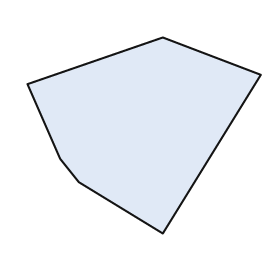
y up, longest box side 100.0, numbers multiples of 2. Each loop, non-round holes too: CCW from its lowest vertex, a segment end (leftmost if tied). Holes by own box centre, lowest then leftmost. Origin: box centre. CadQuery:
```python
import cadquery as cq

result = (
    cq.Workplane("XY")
    .moveTo(8.0, -42.0)
    .lineTo(50.0, 26.0)
    .lineTo(8.0, 42.0)
    .lineTo(-50.0, 22.0)
    .lineTo(-36.0, -10.0)
    .lineTo(-28.0, -20.0)
    .close()
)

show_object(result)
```